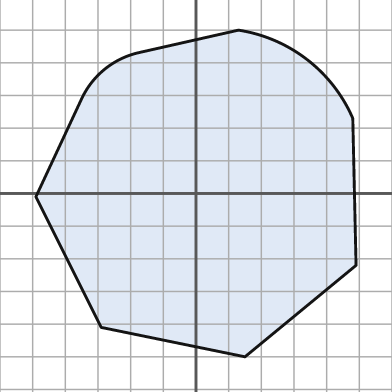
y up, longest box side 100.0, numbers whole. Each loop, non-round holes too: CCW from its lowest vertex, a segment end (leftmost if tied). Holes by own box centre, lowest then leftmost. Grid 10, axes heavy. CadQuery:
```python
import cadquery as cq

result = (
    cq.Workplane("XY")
    .moveTo(15.0, -50.0)
    .lineTo(49.0, -22.0)
    .lineTo(48.0, 23.0)
    .threePointArc((34.0, 41.0), (13.0, 50.0))
    .lineTo(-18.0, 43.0)
    .threePointArc((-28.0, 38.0), (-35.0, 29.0))
    .lineTo(-49.0, -1.0)
    .lineTo(-29.0, -41.0)
    .close()
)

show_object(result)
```